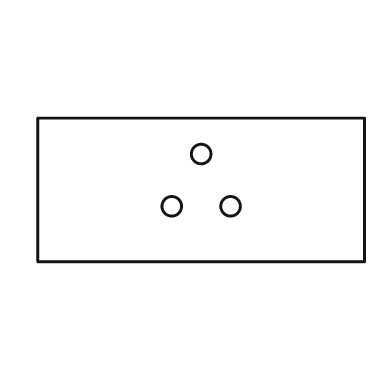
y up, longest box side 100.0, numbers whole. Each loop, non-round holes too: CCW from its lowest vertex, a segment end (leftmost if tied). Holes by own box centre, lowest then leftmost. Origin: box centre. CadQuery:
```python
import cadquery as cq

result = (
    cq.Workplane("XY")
    .moveTo(-50.0, -22.0)
    .lineTo(50.0, -22.0)
    .lineTo(50.0, 22.0)
    .lineTo(-50.0, 22.0)
    .close()
    .moveTo(-9.0, -5.0)
    .circle(3.0)
    .moveTo(9.0, -5.0)
    .circle(3.0)
    .moveTo(0.0, 11.0)
    .circle(3.0)
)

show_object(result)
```